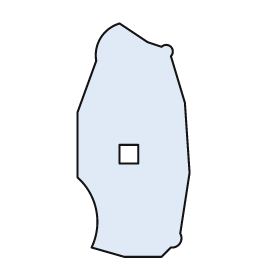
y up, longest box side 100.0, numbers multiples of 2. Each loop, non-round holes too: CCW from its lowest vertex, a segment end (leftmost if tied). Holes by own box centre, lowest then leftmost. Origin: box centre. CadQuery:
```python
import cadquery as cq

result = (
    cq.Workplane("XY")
    .moveTo(-4.0, -50.0)
    .lineTo(12.0, -50.0)
    .lineTo(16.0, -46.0)
    .threePointArc((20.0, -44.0), (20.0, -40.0))
    .lineTo(24.0, -14.0)
    .lineTo(22.0, 16.0)
    .lineTo(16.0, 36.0)
    .threePointArc((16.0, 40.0), (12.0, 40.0))
    .lineTo(6.0, 42.0)
    .lineTo(-6.0, 50.0)
    .threePointArc((-14.0, 44.0), (-16.0, 34.0))
    .lineTo(-24.0, 12.0)
    .lineTo(-24.0, -16.0)
    .threePointArc((-16.0, -30.0), (-18.0, -46.0))
    .close()
    .moveTo(-6.0, -10.0)
    .lineTo(2.0, -10.0)
    .lineTo(2.0, -2.0)
    .lineTo(-6.0, -2.0)
    .close()
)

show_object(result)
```